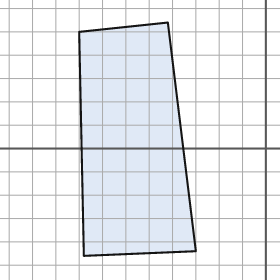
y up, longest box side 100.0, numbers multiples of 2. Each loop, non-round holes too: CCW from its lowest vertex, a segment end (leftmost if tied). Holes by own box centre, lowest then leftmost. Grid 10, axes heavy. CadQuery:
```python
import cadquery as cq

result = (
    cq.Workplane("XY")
    .moveTo(-78.0, -46.0)
    .lineTo(-30.0, -44.0)
    .lineTo(-42.0, 54.0)
    .lineTo(-80.0, 50.0)
    .close()
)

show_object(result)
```